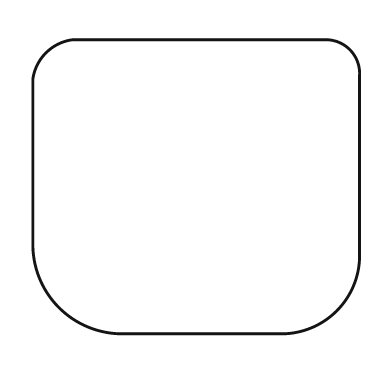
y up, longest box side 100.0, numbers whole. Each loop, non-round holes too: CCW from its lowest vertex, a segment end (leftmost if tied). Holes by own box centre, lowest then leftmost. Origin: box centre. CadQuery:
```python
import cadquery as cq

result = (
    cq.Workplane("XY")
    .moveTo(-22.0, -45.0)
    .lineTo(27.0, -45.0)
    .threePointArc((43.0, -38.0), (50.0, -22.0))
    .lineTo(50.0, 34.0)
    .threePointArc((47.0, 42.0), (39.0, 45.0))
    .lineTo(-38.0, 45.0)
    .threePointArc((-46.0, 41.0), (-50.0, 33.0))
    .lineTo(-50.0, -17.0)
    .threePointArc((-42.0, -37.0), (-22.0, -45.0))
    .close()
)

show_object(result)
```